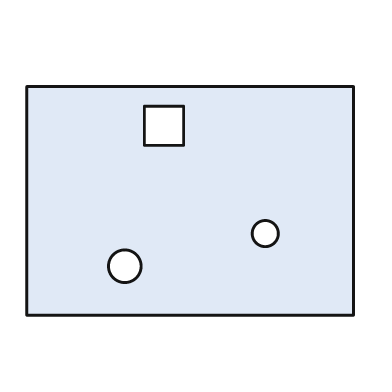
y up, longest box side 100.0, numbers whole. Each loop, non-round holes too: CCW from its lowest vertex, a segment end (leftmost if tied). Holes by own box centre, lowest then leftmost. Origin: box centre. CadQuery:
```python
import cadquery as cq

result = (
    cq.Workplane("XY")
    .moveTo(-50.0, -35.0)
    .lineTo(50.0, -35.0)
    .lineTo(50.0, 35.0)
    .lineTo(-50.0, 35.0)
    .close()
    .moveTo(-20.0, -20.0)
    .circle(5.0)
    .moveTo(23.0, -10.0)
    .circle(4.0)
    .moveTo(-14.0, 17.0)
    .lineTo(-2.0, 17.0)
    .lineTo(-2.0, 29.0)
    .lineTo(-14.0, 29.0)
    .close()
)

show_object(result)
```